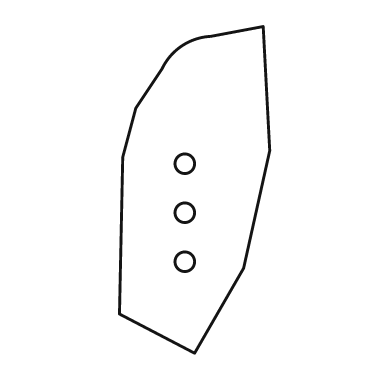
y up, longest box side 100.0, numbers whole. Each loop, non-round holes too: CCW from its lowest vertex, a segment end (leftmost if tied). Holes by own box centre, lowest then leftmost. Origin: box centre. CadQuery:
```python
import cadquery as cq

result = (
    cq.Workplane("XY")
    .moveTo(0.0, -50.0)
    .lineTo(15.0, -24.0)
    .lineTo(23.0, 12.0)
    .lineTo(21.0, 50.0)
    .lineTo(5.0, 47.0)
    .threePointArc((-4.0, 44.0), (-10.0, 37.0))
    .lineTo(-18.0, 25.0)
    .lineTo(-22.0, 10.0)
    .lineTo(-23.0, -38.0)
    .close()
    .moveTo(-3.0, -22.0)
    .circle(3.0)
    .moveTo(-3.0, -7.0)
    .circle(3.0)
    .moveTo(-3.0, 8.0)
    .circle(3.0)
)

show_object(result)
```